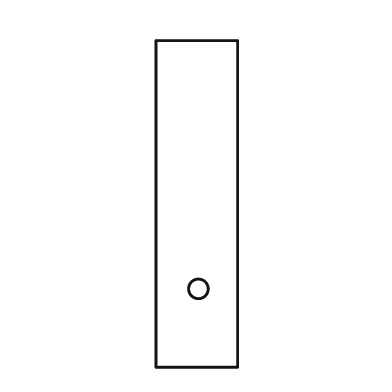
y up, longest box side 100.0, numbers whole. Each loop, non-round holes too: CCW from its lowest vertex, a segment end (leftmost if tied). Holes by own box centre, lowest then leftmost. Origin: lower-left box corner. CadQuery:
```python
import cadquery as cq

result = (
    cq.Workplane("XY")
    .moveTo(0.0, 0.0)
    .lineTo(25.0, 0.0)
    .lineTo(25.0, 100.0)
    .lineTo(0.0, 100.0)
    .close()
    .moveTo(13.0, 24.0)
    .circle(3.0)
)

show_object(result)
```